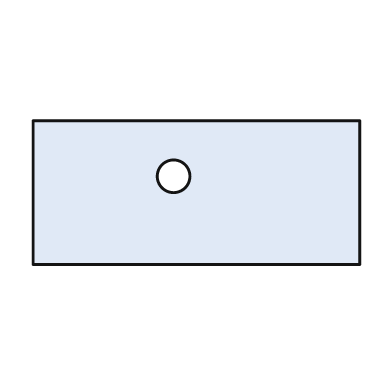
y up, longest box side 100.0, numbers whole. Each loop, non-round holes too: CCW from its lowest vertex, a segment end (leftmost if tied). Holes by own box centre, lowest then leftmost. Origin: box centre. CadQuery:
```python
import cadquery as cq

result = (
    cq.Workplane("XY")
    .moveTo(-50.0, -22.0)
    .lineTo(50.0, -22.0)
    .lineTo(50.0, 22.0)
    .lineTo(-50.0, 22.0)
    .close()
    .moveTo(-7.0, 5.0)
    .circle(5.0)
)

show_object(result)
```